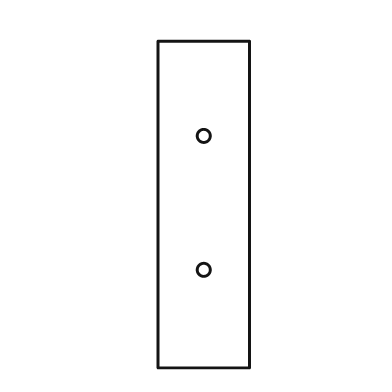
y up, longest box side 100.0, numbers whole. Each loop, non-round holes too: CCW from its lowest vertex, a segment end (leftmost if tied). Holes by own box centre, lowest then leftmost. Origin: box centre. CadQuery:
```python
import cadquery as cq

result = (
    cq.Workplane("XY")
    .moveTo(-14.0, -50.0)
    .lineTo(14.0, -50.0)
    .lineTo(14.0, 50.0)
    .lineTo(-14.0, 50.0)
    .close()
    .moveTo(0.0, -20.0)
    .circle(2.0)
    .moveTo(0.0, 21.0)
    .circle(2.0)
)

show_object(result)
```